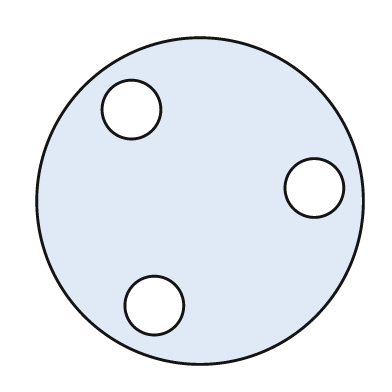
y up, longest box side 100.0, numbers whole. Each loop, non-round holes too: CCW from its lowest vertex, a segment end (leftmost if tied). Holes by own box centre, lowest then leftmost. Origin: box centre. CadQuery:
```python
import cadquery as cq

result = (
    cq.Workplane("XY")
    .moveTo(0.0, 0.0)
    .circle(50.0)
    .moveTo(-14.0, -32.0)
    .circle(9.0)
    .moveTo(35.0, 4.0)
    .circle(9.0)
    .moveTo(-21.0, 28.0)
    .circle(9.0)
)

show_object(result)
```